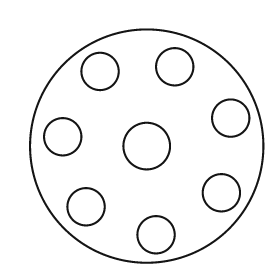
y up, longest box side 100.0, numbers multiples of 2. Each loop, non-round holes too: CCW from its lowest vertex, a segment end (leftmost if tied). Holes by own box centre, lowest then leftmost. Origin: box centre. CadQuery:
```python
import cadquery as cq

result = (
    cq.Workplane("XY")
    .moveTo(0.0, 0.0)
    .circle(50.0)
    .moveTo(4.0, -38.0)
    .circle(8.0)
    .moveTo(-26.0, -26.0)
    .circle(8.0)
    .moveTo(32.0, -20.0)
    .circle(8.0)
    .moveTo(0.0, 0.0)
    .circle(10.0)
    .moveTo(-36.0, 4.0)
    .circle(8.0)
    .moveTo(36.0, 12.0)
    .circle(8.0)
    .moveTo(-20.0, 32.0)
    .circle(8.0)
    .moveTo(12.0, 34.0)
    .circle(8.0)
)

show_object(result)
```